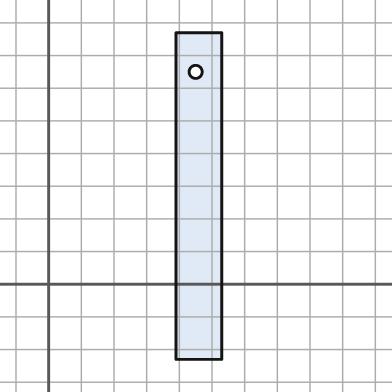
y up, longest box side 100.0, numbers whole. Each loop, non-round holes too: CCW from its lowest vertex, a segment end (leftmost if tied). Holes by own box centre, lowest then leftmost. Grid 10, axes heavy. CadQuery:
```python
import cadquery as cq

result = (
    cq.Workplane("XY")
    .moveTo(39.0, -23.0)
    .lineTo(53.0, -23.0)
    .lineTo(53.0, 77.0)
    .lineTo(39.0, 77.0)
    .close()
    .moveTo(45.0, 65.0)
    .circle(2.0)
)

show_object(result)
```